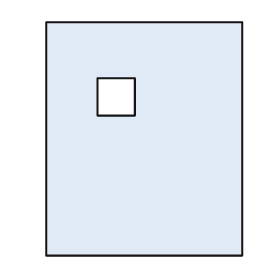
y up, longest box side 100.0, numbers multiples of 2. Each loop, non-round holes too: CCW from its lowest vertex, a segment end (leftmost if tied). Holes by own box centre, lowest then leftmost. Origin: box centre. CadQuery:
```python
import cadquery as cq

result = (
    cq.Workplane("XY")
    .moveTo(-42.0, -50.0)
    .lineTo(42.0, -50.0)
    .lineTo(42.0, 50.0)
    .lineTo(-42.0, 50.0)
    .close()
    .moveTo(-20.0, 10.0)
    .lineTo(-4.0, 10.0)
    .lineTo(-4.0, 26.0)
    .lineTo(-20.0, 26.0)
    .close()
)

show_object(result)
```